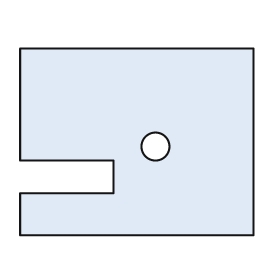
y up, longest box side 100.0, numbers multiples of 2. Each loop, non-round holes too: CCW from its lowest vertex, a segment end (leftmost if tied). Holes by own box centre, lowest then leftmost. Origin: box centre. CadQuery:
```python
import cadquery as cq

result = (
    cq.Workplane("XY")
    .moveTo(-50.0, -40.0)
    .lineTo(50.0, -40.0)
    .lineTo(50.0, 40.0)
    .lineTo(-50.0, 40.0)
    .lineTo(-50.0, -8.0)
    .lineTo(-10.0, -8.0)
    .lineTo(-10.0, -22.0)
    .lineTo(-50.0, -22.0)
    .close()
    .moveTo(8.0, -2.0)
    .circle(6.0)
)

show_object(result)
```